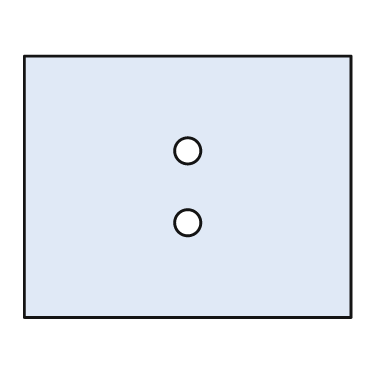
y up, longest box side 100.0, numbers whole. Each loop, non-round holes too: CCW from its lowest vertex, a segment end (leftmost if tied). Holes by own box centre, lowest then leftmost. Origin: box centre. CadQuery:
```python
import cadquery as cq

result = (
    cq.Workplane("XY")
    .moveTo(-50.0, -40.0)
    .lineTo(50.0, -40.0)
    .lineTo(50.0, 40.0)
    .lineTo(-50.0, 40.0)
    .close()
    .moveTo(0.0, -11.0)
    .circle(4.0)
    .moveTo(0.0, 11.0)
    .circle(4.0)
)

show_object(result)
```